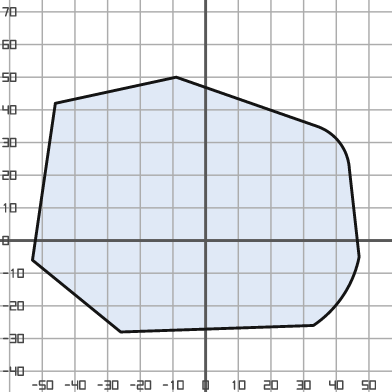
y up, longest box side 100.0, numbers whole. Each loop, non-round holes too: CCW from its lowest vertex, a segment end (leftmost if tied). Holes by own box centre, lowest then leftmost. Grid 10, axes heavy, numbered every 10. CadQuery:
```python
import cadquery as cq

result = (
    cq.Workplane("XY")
    .moveTo(-26.0, -28.0)
    .lineTo(33.0, -26.0)
    .threePointArc((42.0, -17.0), (47.0, -5.0))
    .lineTo(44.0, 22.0)
    .threePointArc((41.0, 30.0), (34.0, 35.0))
    .lineTo(-9.0, 50.0)
    .lineTo(-46.0, 42.0)
    .lineTo(-53.0, -6.0)
    .close()
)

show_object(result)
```